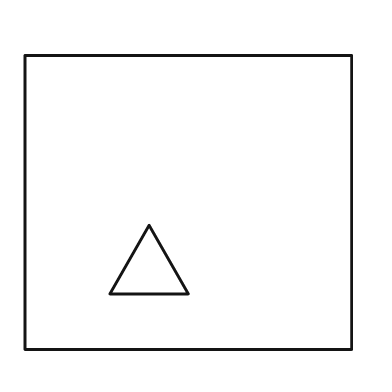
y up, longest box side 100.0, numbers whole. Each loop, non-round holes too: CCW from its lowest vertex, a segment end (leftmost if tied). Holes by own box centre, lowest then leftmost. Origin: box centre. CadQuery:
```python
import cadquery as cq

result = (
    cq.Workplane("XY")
    .moveTo(-50.0, -45.0)
    .lineTo(50.0, -45.0)
    .lineTo(50.0, 45.0)
    .lineTo(-50.0, 45.0)
    .close()
    .moveTo(-24.0, -28.0)
    .lineTo(0.0, -28.0)
    .lineTo(-12.0, -7.0)
    .close()
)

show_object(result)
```